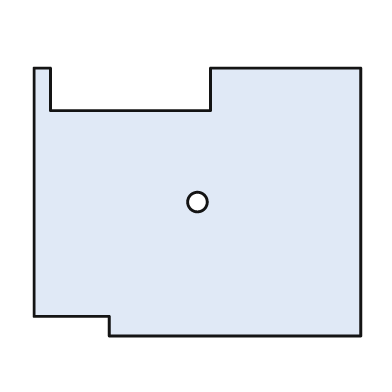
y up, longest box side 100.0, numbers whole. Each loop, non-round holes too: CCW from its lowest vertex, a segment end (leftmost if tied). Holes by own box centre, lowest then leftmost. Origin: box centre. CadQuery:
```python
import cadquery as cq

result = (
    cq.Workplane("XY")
    .moveTo(-27.0, -41.0)
    .lineTo(50.0, -41.0)
    .lineTo(50.0, 41.0)
    .lineTo(4.0, 41.0)
    .lineTo(4.0, 28.0)
    .lineTo(-45.0, 28.0)
    .lineTo(-45.0, 41.0)
    .lineTo(-50.0, 41.0)
    .lineTo(-50.0, -35.0)
    .lineTo(-27.0, -35.0)
    .close()
    .moveTo(0.0, 0.0)
    .circle(3.0)
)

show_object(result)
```